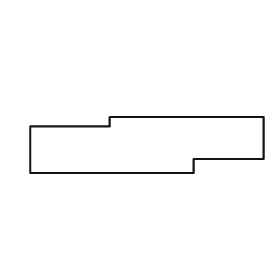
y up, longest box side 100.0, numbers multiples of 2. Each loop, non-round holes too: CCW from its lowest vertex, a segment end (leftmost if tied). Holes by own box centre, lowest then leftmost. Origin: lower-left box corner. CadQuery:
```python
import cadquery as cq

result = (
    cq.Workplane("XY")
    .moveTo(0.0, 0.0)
    .lineTo(70.0, 0.0)
    .lineTo(70.0, 6.0)
    .lineTo(100.0, 6.0)
    .lineTo(100.0, 24.0)
    .lineTo(34.0, 24.0)
    .lineTo(34.0, 20.0)
    .lineTo(0.0, 20.0)
    .close()
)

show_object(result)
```